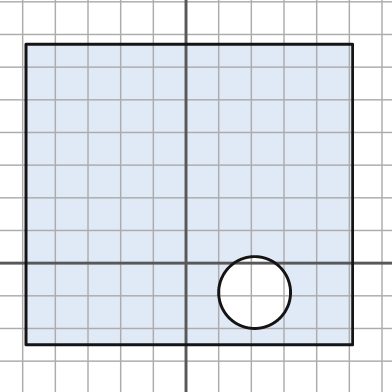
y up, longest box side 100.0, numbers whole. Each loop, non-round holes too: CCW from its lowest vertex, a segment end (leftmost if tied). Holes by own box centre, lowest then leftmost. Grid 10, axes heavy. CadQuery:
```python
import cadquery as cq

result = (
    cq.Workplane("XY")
    .moveTo(-49.0, -25.0)
    .lineTo(51.0, -25.0)
    .lineTo(51.0, 67.0)
    .lineTo(-49.0, 67.0)
    .close()
    .moveTo(21.0, -9.0)
    .circle(11.0)
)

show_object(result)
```